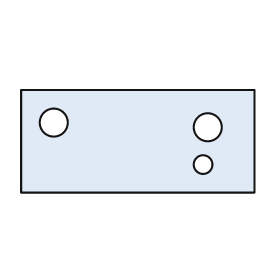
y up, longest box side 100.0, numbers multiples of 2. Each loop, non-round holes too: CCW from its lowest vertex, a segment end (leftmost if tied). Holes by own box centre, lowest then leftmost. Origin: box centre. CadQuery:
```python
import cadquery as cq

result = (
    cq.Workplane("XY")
    .moveTo(-50.0, -22.0)
    .lineTo(50.0, -22.0)
    .lineTo(50.0, 22.0)
    .lineTo(-50.0, 22.0)
    .close()
    .moveTo(28.0, -10.0)
    .circle(4.0)
    .moveTo(30.0, 6.0)
    .circle(6.0)
    .moveTo(-36.0, 8.0)
    .circle(6.0)
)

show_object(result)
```